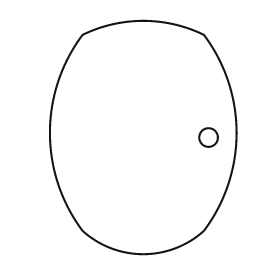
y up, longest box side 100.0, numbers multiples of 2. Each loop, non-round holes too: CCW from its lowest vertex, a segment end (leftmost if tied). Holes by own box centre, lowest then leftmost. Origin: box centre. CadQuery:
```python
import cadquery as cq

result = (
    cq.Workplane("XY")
    .moveTo(-26.0, -40.0)
    .threePointArc((0.0, -50.0), (26.0, -40.0))
    .threePointArc((40.0, 2.0), (26.0, 44.0))
    .threePointArc((0.0, 50.0), (-26.0, 44.0))
    .threePointArc((-40.0, 2.0), (-26.0, -40.0))
    .close()
    .moveTo(28.0, 0.0)
    .circle(4.0)
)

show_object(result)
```